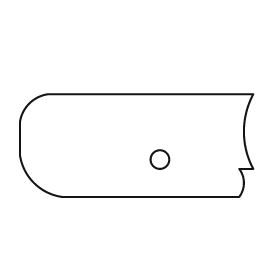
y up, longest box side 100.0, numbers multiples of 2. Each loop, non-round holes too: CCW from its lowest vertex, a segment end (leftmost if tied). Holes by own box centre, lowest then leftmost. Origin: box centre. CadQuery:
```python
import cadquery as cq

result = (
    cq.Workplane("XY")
    .moveTo(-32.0, -22.0)
    .lineTo(44.0, -22.0)
    .threePointArc((46.0, -16.0), (44.0, -10.0))
    .lineTo(50.0, -10.0)
    .threePointArc((46.0, 6.0), (50.0, 22.0))
    .lineTo(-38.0, 22.0)
    .threePointArc((-46.0, 18.0), (-50.0, 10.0))
    .lineTo(-50.0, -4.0)
    .threePointArc((-44.0, -16.0), (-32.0, -22.0))
    .close()
    .moveTo(10.0, -6.0)
    .circle(4.0)
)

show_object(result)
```